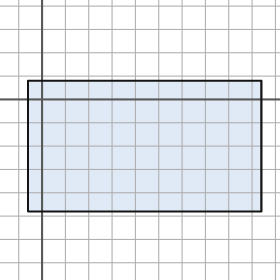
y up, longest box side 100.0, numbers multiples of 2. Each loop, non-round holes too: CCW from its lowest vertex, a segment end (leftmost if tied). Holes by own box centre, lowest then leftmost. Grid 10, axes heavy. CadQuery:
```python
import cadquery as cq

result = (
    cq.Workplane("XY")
    .moveTo(-6.0, -48.0)
    .lineTo(94.0, -48.0)
    .lineTo(94.0, 8.0)
    .lineTo(-6.0, 8.0)
    .close()
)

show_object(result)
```